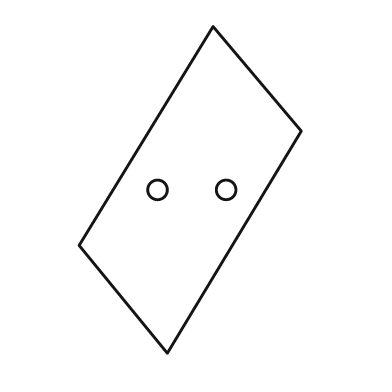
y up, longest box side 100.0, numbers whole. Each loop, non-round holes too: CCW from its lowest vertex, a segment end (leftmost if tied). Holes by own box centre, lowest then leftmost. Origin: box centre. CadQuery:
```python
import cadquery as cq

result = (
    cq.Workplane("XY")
    .moveTo(-7.0, -50.0)
    .lineTo(34.0, 18.0)
    .lineTo(7.0, 50.0)
    .lineTo(-34.0, -17.0)
    .close()
    .moveTo(-10.0, 0.0)
    .circle(3.0)
    .moveTo(11.0, 0.0)
    .circle(3.0)
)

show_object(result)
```